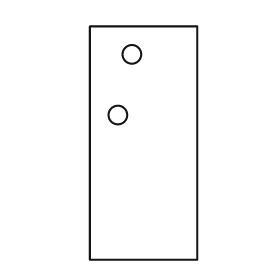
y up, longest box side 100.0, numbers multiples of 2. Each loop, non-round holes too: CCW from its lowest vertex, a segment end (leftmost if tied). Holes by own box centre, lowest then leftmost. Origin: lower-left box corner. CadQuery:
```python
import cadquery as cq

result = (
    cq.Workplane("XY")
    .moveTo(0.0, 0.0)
    .lineTo(46.0, 0.0)
    .lineTo(46.0, 100.0)
    .lineTo(0.0, 100.0)
    .close()
    .moveTo(12.0, 62.0)
    .circle(4.0)
    .moveTo(18.0, 88.0)
    .circle(4.0)
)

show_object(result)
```